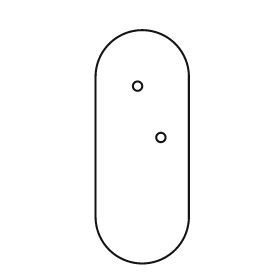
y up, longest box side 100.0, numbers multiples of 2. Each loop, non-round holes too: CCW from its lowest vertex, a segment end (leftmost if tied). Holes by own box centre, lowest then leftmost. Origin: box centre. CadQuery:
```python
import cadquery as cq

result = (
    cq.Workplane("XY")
    .moveTo(-20.0, -30.0)
    .threePointArc((0.0, -50.0), (20.0, -30.0))
    .lineTo(20.0, 30.0)
    .threePointArc((0.0, 50.0), (-20.0, 30.0))
    .close()
    .moveTo(8.0, 4.0)
    .circle(2.0)
    .moveTo(-2.0, 26.0)
    .circle(2.0)
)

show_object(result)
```